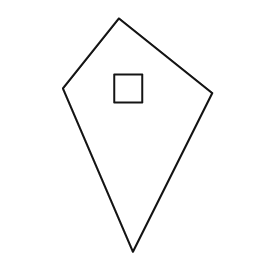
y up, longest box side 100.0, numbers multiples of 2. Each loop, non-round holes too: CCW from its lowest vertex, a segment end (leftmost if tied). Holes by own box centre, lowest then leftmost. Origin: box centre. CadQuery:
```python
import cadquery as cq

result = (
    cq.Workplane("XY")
    .moveTo(-2.0, -50.0)
    .lineTo(32.0, 18.0)
    .lineTo(-8.0, 50.0)
    .lineTo(-32.0, 20.0)
    .close()
    .moveTo(-10.0, 14.0)
    .lineTo(2.0, 14.0)
    .lineTo(2.0, 26.0)
    .lineTo(-10.0, 26.0)
    .close()
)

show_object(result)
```